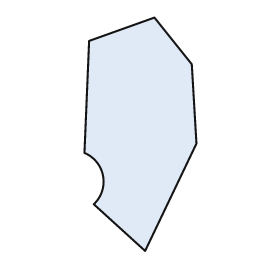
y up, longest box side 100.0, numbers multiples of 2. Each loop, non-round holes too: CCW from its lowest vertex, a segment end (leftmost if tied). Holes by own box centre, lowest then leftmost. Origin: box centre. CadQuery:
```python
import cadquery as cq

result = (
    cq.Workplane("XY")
    .moveTo(2.0, -50.0)
    .lineTo(24.0, -4.0)
    .lineTo(22.0, 30.0)
    .lineTo(6.0, 50.0)
    .lineTo(-22.0, 40.0)
    .lineTo(-24.0, -8.0)
    .threePointArc((-16.0, -18.0), (-20.0, -30.0))
    .close()
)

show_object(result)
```